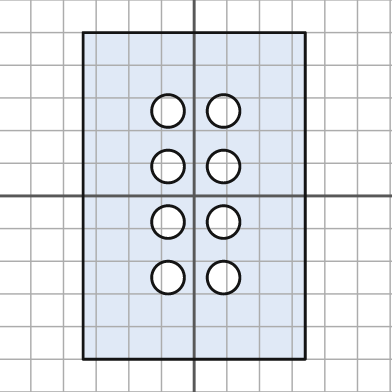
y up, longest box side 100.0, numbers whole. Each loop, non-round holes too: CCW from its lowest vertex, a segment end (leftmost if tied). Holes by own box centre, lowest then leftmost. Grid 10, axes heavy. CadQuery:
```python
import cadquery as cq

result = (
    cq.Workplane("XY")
    .moveTo(-34.0, -50.0)
    .lineTo(34.0, -50.0)
    .lineTo(34.0, 50.0)
    .lineTo(-34.0, 50.0)
    .close()
    .moveTo(-8.0, -25.0)
    .circle(5.0)
    .moveTo(9.0, -25.0)
    .circle(5.0)
    .moveTo(-8.0, -8.0)
    .circle(5.0)
    .moveTo(9.0, -8.0)
    .circle(5.0)
    .moveTo(-8.0, 9.0)
    .circle(5.0)
    .moveTo(9.0, 9.0)
    .circle(5.0)
    .moveTo(-8.0, 26.0)
    .circle(5.0)
    .moveTo(9.0, 26.0)
    .circle(5.0)
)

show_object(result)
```